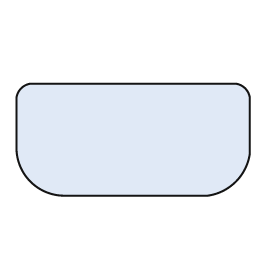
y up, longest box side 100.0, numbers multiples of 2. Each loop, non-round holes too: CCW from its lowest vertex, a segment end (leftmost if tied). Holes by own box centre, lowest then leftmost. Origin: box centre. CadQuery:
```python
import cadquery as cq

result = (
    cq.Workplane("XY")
    .moveTo(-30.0, -24.0)
    .lineTo(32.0, -24.0)
    .threePointArc((44.0, -18.0), (50.0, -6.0))
    .lineTo(50.0, 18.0)
    .threePointArc((48.0, 22.0), (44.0, 24.0))
    .lineTo(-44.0, 24.0)
    .threePointArc((-48.0, 22.0), (-50.0, 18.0))
    .lineTo(-50.0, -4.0)
    .threePointArc((-44.0, -18.0), (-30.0, -24.0))
    .close()
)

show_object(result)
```